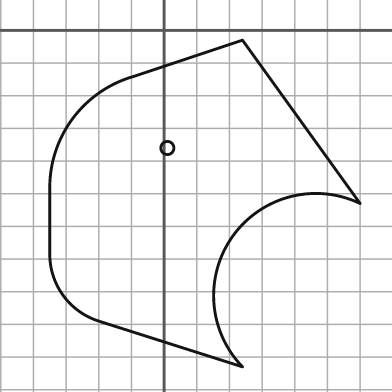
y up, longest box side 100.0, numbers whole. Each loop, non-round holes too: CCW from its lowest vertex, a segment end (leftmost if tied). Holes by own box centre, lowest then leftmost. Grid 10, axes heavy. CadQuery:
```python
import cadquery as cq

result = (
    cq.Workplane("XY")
    .moveTo(24.0, -103.0)
    .threePointArc((21.0, -63.0), (60.0, -53.0))
    .lineTo(24.0, -3.0)
    .lineTo(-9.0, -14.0)
    .threePointArc((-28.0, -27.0), (-35.0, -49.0))
    .lineTo(-35.0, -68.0)
    .threePointArc((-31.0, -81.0), (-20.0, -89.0))
    .close()
    .moveTo(1.0, -36.0)
    .circle(2.0)
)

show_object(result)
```